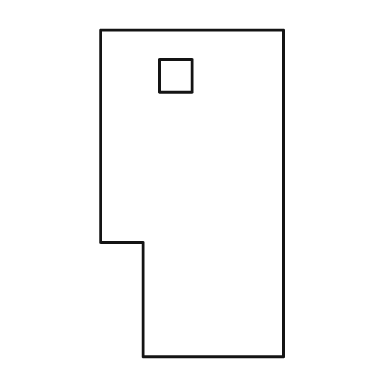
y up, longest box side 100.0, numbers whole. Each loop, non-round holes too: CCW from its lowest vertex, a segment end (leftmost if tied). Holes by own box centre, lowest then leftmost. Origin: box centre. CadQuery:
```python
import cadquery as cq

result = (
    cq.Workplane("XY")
    .moveTo(-15.0, -50.0)
    .lineTo(28.0, -50.0)
    .lineTo(28.0, 50.0)
    .lineTo(-28.0, 50.0)
    .lineTo(-28.0, -15.0)
    .lineTo(-15.0, -15.0)
    .close()
    .moveTo(-10.0, 31.0)
    .lineTo(0.0, 31.0)
    .lineTo(0.0, 41.0)
    .lineTo(-10.0, 41.0)
    .close()
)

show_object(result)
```